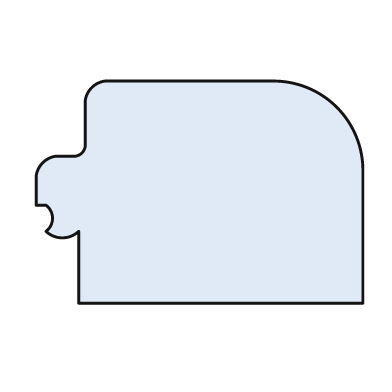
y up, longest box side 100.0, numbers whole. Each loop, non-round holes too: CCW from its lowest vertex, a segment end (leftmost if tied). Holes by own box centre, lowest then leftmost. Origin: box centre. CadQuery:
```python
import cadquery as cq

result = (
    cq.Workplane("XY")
    .moveTo(-37.0, -34.0)
    .lineTo(50.0, -34.0)
    .lineTo(50.0, 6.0)
    .threePointArc((42.0, 26.0), (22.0, 34.0))
    .lineTo(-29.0, 34.0)
    .threePointArc((-33.0, 32.0), (-35.0, 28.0))
    .lineTo(-35.0, 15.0)
    .threePointArc((-36.0, 12.0), (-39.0, 11.0))
    .lineTo(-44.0, 11.0)
    .threePointArc((-48.0, 9.0), (-50.0, 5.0))
    .lineTo(-50.0, -4.0)
    .lineTo(-47.0, -4.0)
    .threePointArc((-45.0, -8.0), (-47.0, -12.0))
    .threePointArc((-42.0, -14.0), (-37.0, -12.0))
    .close()
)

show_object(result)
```